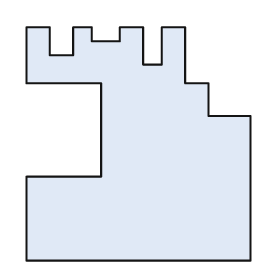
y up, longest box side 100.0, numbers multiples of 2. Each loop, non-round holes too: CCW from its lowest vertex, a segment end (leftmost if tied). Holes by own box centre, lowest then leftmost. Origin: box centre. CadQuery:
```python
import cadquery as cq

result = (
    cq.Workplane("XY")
    .moveTo(-48.0, -50.0)
    .lineTo(48.0, -50.0)
    .lineTo(48.0, 12.0)
    .lineTo(30.0, 12.0)
    .lineTo(30.0, 26.0)
    .lineTo(20.0, 26.0)
    .lineTo(20.0, 50.0)
    .lineTo(10.0, 50.0)
    .lineTo(10.0, 34.0)
    .lineTo(2.0, 34.0)
    .lineTo(2.0, 50.0)
    .lineTo(-8.0, 50.0)
    .lineTo(-8.0, 44.0)
    .lineTo(-20.0, 44.0)
    .lineTo(-20.0, 50.0)
    .lineTo(-28.0, 50.0)
    .lineTo(-28.0, 38.0)
    .lineTo(-38.0, 38.0)
    .lineTo(-38.0, 50.0)
    .lineTo(-48.0, 50.0)
    .lineTo(-48.0, 26.0)
    .lineTo(-16.0, 26.0)
    .lineTo(-16.0, -14.0)
    .lineTo(-48.0, -14.0)
    .close()
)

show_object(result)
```